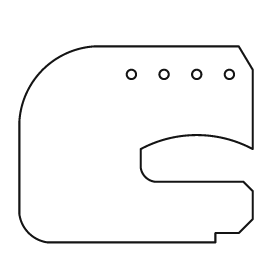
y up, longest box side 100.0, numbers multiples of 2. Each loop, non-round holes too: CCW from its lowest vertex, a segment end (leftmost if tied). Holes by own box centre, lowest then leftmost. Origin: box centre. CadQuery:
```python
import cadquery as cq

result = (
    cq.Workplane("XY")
    .moveTo(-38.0, -42.0)
    .lineTo(34.0, -42.0)
    .lineTo(34.0, -38.0)
    .lineTo(44.0, -38.0)
    .lineTo(50.0, -32.0)
    .lineTo(50.0, -20.0)
    .lineTo(46.0, -16.0)
    .lineTo(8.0, -16.0)
    .threePointArc((4.0, -14.0), (2.0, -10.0))
    .lineTo(2.0, -2.0)
    .threePointArc((26.0, 4.0), (50.0, -2.0))
    .lineTo(50.0, 32.0)
    .lineTo(44.0, 42.0)
    .lineTo(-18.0, 42.0)
    .threePointArc((-40.0, 32.0), (-50.0, 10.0))
    .lineTo(-50.0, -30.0)
    .threePointArc((-46.0, -38.0), (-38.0, -42.0))
    .close()
    .moveTo(-2.0, 30.0)
    .circle(2.0)
    .moveTo(12.0, 30.0)
    .circle(2.0)
    .moveTo(26.0, 30.0)
    .circle(2.0)
    .moveTo(40.0, 30.0)
    .circle(2.0)
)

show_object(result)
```